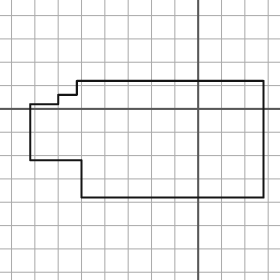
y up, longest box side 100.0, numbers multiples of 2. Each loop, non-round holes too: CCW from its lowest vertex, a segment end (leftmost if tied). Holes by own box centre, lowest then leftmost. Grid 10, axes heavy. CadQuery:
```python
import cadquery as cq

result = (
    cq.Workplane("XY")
    .moveTo(-50.0, -38.0)
    .lineTo(28.0, -38.0)
    .lineTo(28.0, 12.0)
    .lineTo(-52.0, 12.0)
    .lineTo(-52.0, 6.0)
    .lineTo(-60.0, 6.0)
    .lineTo(-60.0, 2.0)
    .lineTo(-72.0, 2.0)
    .lineTo(-72.0, -22.0)
    .lineTo(-50.0, -22.0)
    .close()
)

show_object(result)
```